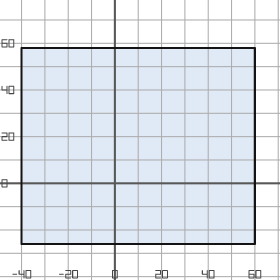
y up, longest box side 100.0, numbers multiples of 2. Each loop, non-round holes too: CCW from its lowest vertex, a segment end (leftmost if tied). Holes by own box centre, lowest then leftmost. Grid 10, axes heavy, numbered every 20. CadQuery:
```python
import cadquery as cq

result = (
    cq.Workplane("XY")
    .moveTo(-40.0, -26.0)
    .lineTo(60.0, -26.0)
    .lineTo(60.0, 58.0)
    .lineTo(-40.0, 58.0)
    .close()
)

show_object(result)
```